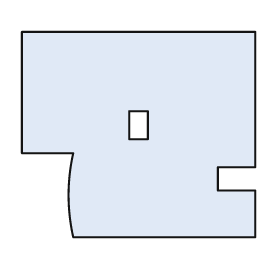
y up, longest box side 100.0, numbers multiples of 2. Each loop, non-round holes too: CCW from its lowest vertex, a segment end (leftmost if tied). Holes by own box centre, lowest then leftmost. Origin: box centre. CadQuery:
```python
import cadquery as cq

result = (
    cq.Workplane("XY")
    .moveTo(-28.0, -44.0)
    .lineTo(50.0, -44.0)
    .lineTo(50.0, -24.0)
    .lineTo(34.0, -24.0)
    .lineTo(34.0, -14.0)
    .lineTo(50.0, -14.0)
    .lineTo(50.0, 44.0)
    .lineTo(-50.0, 44.0)
    .lineTo(-50.0, -8.0)
    .lineTo(-28.0, -8.0)
    .threePointArc((-30.0, -26.0), (-28.0, -44.0))
    .close()
    .moveTo(-4.0, -2.0)
    .lineTo(4.0, -2.0)
    .lineTo(4.0, 10.0)
    .lineTo(-4.0, 10.0)
    .close()
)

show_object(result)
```